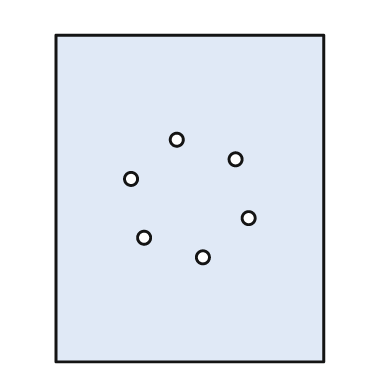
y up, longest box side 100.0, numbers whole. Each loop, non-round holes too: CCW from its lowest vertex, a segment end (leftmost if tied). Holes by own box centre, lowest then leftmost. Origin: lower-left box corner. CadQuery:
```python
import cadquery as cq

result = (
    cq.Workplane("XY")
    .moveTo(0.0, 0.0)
    .lineTo(82.0, 0.0)
    .lineTo(82.0, 100.0)
    .lineTo(0.0, 100.0)
    .close()
    .moveTo(45.0, 32.0)
    .circle(2.0)
    .moveTo(27.0, 38.0)
    .circle(2.0)
    .moveTo(59.0, 44.0)
    .circle(2.0)
    .moveTo(23.0, 56.0)
    .circle(2.0)
    .moveTo(55.0, 62.0)
    .circle(2.0)
    .moveTo(37.0, 68.0)
    .circle(2.0)
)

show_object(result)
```